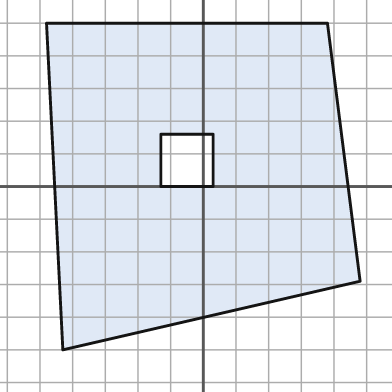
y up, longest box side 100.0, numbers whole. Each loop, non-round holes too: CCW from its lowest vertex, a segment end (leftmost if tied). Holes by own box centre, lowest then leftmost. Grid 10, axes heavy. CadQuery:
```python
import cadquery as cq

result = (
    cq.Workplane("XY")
    .moveTo(-43.0, -50.0)
    .lineTo(48.0, -29.0)
    .lineTo(38.0, 50.0)
    .lineTo(-48.0, 50.0)
    .close()
    .moveTo(-13.0, 0.0)
    .lineTo(3.0, 0.0)
    .lineTo(3.0, 16.0)
    .lineTo(-13.0, 16.0)
    .close()
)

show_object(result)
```